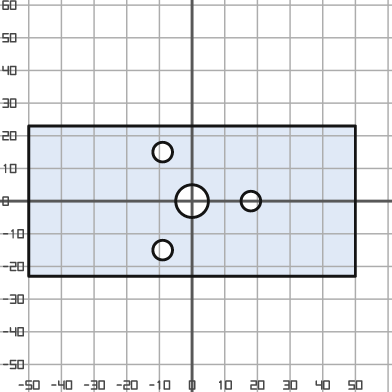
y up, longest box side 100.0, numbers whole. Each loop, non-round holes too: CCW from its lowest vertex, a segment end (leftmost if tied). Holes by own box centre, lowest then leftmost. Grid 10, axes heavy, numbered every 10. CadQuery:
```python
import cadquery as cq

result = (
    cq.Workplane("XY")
    .moveTo(-50.0, -23.0)
    .lineTo(50.0, -23.0)
    .lineTo(50.0, 23.0)
    .lineTo(-50.0, 23.0)
    .close()
    .moveTo(-9.0, -15.0)
    .circle(3.0)
    .moveTo(0.0, 0.0)
    .circle(5.0)
    .moveTo(18.0, 0.0)
    .circle(3.0)
    .moveTo(-9.0, 15.0)
    .circle(3.0)
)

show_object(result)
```